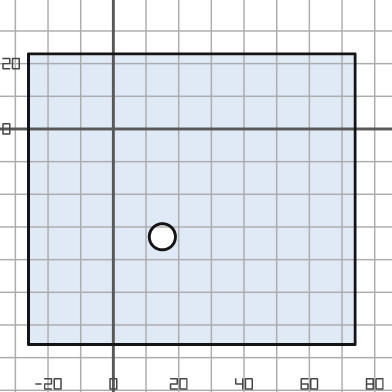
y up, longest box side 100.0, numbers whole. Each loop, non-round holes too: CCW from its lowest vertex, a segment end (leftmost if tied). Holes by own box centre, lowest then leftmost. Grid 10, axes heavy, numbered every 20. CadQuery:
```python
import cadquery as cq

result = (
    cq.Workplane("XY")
    .moveTo(-26.0, -66.0)
    .lineTo(74.0, -66.0)
    .lineTo(74.0, 23.0)
    .lineTo(-26.0, 23.0)
    .close()
    .moveTo(15.0, -33.0)
    .circle(4.0)
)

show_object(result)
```